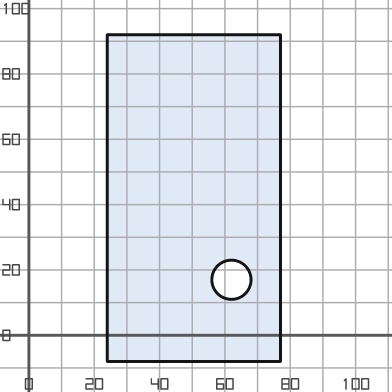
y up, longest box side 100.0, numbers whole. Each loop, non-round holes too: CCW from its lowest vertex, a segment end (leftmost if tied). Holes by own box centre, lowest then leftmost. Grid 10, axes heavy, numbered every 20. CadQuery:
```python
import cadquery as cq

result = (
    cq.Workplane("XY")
    .moveTo(24.0, -8.0)
    .lineTo(77.0, -8.0)
    .lineTo(77.0, 92.0)
    .lineTo(24.0, 92.0)
    .close()
    .moveTo(62.0, 17.0)
    .circle(6.0)
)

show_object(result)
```